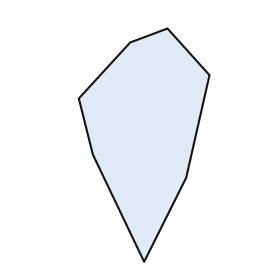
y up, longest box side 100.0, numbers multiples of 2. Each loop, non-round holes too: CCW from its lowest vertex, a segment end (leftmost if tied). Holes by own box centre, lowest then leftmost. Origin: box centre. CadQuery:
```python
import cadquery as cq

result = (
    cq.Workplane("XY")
    .moveTo(0.0, -50.0)
    .lineTo(18.0, -14.0)
    .lineTo(28.0, 30.0)
    .lineTo(10.0, 50.0)
    .lineTo(-6.0, 44.0)
    .lineTo(-28.0, 20.0)
    .lineTo(-22.0, -4.0)
    .close()
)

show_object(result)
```